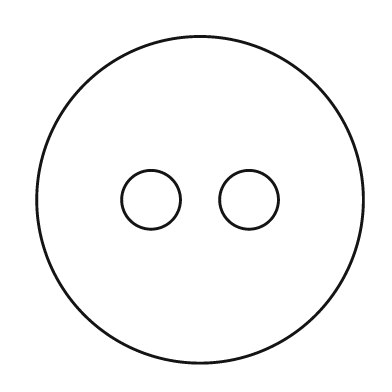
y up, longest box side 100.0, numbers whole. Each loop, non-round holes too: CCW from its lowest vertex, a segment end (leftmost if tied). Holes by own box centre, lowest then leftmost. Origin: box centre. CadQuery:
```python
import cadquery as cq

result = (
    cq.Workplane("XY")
    .moveTo(0.0, 0.0)
    .circle(50.0)
    .moveTo(-15.0, 0.0)
    .circle(9.0)
    .moveTo(15.0, 0.0)
    .circle(9.0)
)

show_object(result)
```